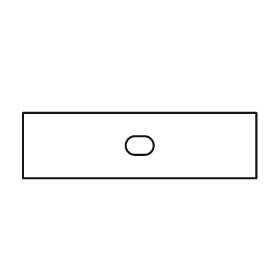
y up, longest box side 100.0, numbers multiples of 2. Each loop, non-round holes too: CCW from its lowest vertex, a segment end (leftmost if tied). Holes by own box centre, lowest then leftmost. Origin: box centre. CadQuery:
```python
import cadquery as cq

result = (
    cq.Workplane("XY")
    .moveTo(-50.0, -14.0)
    .lineTo(50.0, -14.0)
    .lineTo(50.0, 14.0)
    .lineTo(-50.0, 14.0)
    .close()
    .moveTo(-2.0, -4.0)
    .lineTo(2.0, -4.0)
    .threePointArc((6.0, 0.0), (2.0, 4.0))
    .lineTo(-2.0, 4.0)
    .threePointArc((-6.0, 0.0), (-2.0, -4.0))
    .close()
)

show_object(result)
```